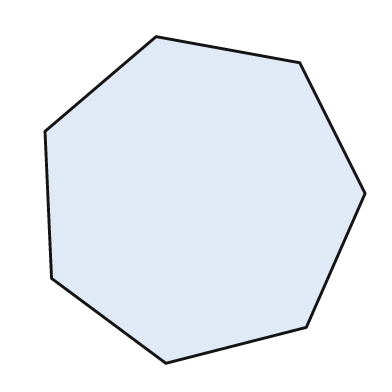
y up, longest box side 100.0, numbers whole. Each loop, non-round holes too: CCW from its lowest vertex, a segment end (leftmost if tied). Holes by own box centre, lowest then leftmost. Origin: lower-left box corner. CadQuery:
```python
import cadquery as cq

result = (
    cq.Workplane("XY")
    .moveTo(37.0, 0.0)
    .lineTo(80.0, 11.0)
    .lineTo(98.0, 52.0)
    .lineTo(78.0, 92.0)
    .lineTo(34.0, 100.0)
    .lineTo(0.0, 71.0)
    .lineTo(2.0, 26.0)
    .close()
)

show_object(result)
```